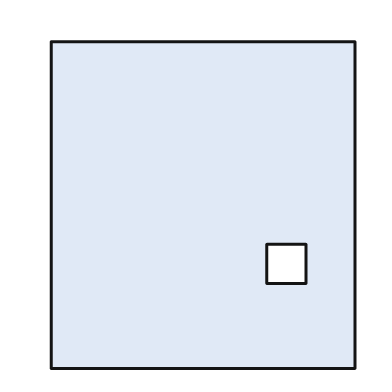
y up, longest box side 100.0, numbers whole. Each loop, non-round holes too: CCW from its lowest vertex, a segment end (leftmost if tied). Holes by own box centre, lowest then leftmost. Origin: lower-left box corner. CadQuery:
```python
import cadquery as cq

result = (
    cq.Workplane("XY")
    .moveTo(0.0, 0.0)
    .lineTo(93.0, 0.0)
    .lineTo(93.0, 100.0)
    .lineTo(0.0, 100.0)
    .close()
    .moveTo(66.0, 26.0)
    .lineTo(78.0, 26.0)
    .lineTo(78.0, 38.0)
    .lineTo(66.0, 38.0)
    .close()
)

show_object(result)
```